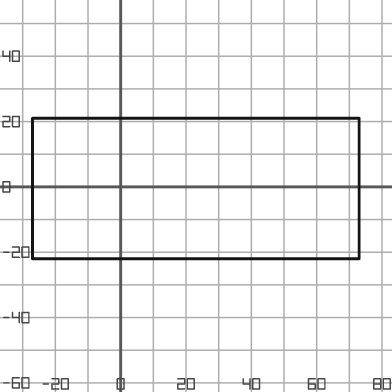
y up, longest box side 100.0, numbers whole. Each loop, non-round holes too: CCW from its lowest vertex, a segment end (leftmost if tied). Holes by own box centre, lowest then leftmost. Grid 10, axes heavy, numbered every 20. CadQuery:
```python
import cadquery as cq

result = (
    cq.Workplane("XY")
    .moveTo(-27.0, -22.0)
    .lineTo(73.0, -22.0)
    .lineTo(73.0, 21.0)
    .lineTo(-27.0, 21.0)
    .close()
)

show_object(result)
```